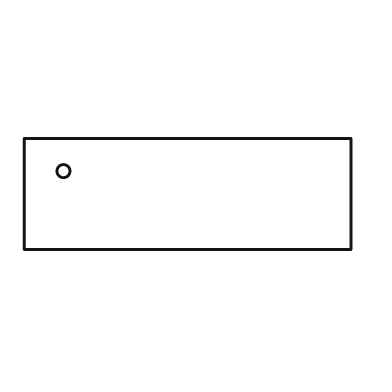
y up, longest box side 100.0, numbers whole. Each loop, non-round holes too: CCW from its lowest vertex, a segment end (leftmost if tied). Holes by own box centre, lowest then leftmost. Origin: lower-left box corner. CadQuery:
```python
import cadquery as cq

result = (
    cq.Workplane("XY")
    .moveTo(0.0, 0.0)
    .lineTo(100.0, 0.0)
    .lineTo(100.0, 34.0)
    .lineTo(0.0, 34.0)
    .close()
    .moveTo(12.0, 24.0)
    .circle(2.0)
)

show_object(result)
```